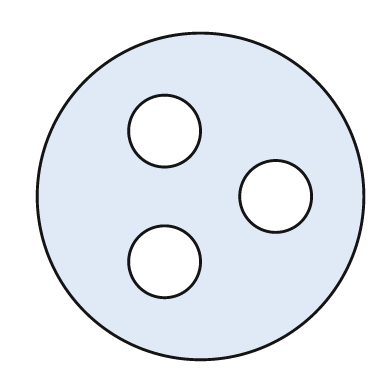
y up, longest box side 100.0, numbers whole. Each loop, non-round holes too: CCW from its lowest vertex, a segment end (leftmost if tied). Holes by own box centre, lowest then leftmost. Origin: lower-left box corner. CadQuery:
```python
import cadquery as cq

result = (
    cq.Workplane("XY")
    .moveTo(50.0, 50.0)
    .circle(50.0)
    .moveTo(39.0, 30.0)
    .circle(11.0)
    .moveTo(73.0, 50.0)
    .circle(11.0)
    .moveTo(39.0, 70.0)
    .circle(11.0)
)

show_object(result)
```